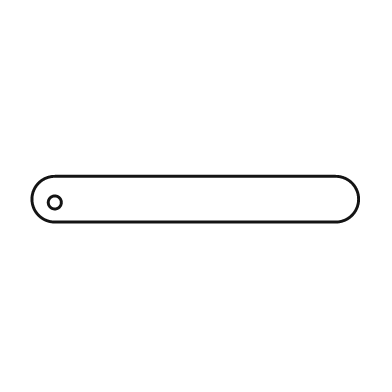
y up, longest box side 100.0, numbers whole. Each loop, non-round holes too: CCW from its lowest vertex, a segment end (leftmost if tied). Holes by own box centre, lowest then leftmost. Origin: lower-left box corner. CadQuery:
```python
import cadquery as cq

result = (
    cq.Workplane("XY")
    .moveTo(7.0, 0.0)
    .lineTo(93.0, 0.0)
    .threePointArc((100.0, 7.0), (93.0, 14.0))
    .lineTo(7.0, 14.0)
    .threePointArc((0.0, 7.0), (7.0, 0.0))
    .close()
    .moveTo(7.0, 6.0)
    .circle(2.0)
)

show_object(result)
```